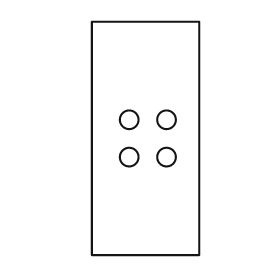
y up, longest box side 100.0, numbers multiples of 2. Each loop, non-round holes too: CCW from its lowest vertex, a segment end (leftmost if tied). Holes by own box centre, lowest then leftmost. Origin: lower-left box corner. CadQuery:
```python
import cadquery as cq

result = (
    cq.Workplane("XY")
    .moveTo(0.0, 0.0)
    .lineTo(46.0, 0.0)
    .lineTo(46.0, 100.0)
    .lineTo(0.0, 100.0)
    .close()
    .moveTo(16.0, 42.0)
    .circle(4.0)
    .moveTo(32.0, 42.0)
    .circle(4.0)
    .moveTo(16.0, 58.0)
    .circle(4.0)
    .moveTo(32.0, 58.0)
    .circle(4.0)
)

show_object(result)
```